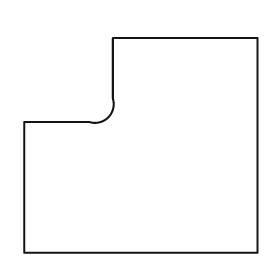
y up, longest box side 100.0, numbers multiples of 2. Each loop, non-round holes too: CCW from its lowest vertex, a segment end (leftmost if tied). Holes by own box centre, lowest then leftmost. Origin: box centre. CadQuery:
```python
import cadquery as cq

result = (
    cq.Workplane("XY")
    .moveTo(-50.0, -46.0)
    .lineTo(50.0, -46.0)
    .lineTo(50.0, 46.0)
    .lineTo(-12.0, 46.0)
    .lineTo(-12.0, 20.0)
    .threePointArc((-14.0, 12.0), (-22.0, 10.0))
    .lineTo(-50.0, 10.0)
    .close()
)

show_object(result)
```